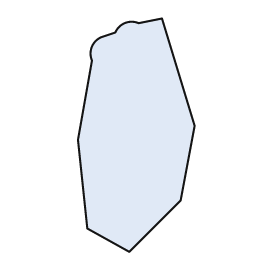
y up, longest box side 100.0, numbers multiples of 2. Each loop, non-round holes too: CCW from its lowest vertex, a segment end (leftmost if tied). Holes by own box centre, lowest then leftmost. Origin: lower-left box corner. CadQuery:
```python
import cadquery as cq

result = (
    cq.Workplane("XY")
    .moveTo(22.0, 0.0)
    .lineTo(44.0, 22.0)
    .lineTo(50.0, 54.0)
    .lineTo(36.0, 100.0)
    .lineTo(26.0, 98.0)
    .threePointArc((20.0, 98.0), (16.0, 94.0))
    .lineTo(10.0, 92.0)
    .threePointArc((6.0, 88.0), (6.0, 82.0))
    .lineTo(0.0, 48.0)
    .lineTo(4.0, 10.0)
    .close()
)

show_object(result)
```